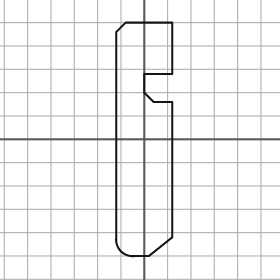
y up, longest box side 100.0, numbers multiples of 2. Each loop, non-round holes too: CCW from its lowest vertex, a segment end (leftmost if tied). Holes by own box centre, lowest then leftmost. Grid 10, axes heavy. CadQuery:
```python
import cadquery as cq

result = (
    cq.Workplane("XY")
    .moveTo(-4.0, -50.0)
    .lineTo(2.0, -50.0)
    .lineTo(12.0, -42.0)
    .lineTo(12.0, 16.0)
    .lineTo(4.0, 16.0)
    .lineTo(0.0, 20.0)
    .lineTo(0.0, 28.0)
    .lineTo(12.0, 28.0)
    .lineTo(12.0, 50.0)
    .lineTo(-8.0, 50.0)
    .lineTo(-12.0, 46.0)
    .lineTo(-12.0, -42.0)
    .threePointArc((-10.0, -48.0), (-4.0, -50.0))
    .close()
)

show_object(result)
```